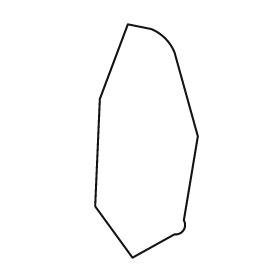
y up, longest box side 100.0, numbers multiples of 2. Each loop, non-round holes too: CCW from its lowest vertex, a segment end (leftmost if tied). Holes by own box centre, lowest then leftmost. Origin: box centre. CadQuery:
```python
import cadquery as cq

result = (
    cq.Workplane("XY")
    .moveTo(-6.0, -50.0)
    .lineTo(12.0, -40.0)
    .threePointArc((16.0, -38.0), (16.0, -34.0))
    .lineTo(22.0, 2.0)
    .lineTo(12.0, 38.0)
    .threePointArc((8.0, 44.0), (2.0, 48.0))
    .lineTo(-8.0, 50.0)
    .lineTo(-20.0, 18.0)
    .lineTo(-22.0, -28.0)
    .close()
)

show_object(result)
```